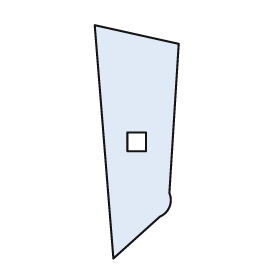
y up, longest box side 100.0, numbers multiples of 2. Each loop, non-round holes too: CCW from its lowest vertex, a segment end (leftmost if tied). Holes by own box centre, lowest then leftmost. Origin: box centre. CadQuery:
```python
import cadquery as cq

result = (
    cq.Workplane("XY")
    .moveTo(-10.0, -50.0)
    .lineTo(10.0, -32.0)
    .threePointArc((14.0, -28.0), (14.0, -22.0))
    .lineTo(18.0, 42.0)
    .lineTo(-18.0, 50.0)
    .close()
    .moveTo(-4.0, -4.0)
    .lineTo(4.0, -4.0)
    .lineTo(4.0, 4.0)
    .lineTo(-4.0, 4.0)
    .close()
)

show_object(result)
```